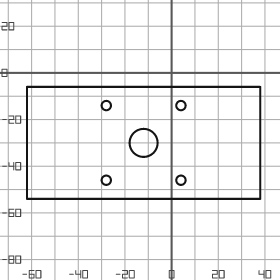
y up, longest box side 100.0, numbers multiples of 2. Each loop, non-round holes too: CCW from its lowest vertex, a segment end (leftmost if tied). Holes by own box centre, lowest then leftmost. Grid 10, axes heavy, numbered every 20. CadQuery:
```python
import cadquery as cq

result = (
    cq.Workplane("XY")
    .moveTo(-62.0, -54.0)
    .lineTo(38.0, -54.0)
    .lineTo(38.0, -6.0)
    .lineTo(-62.0, -6.0)
    .close()
    .moveTo(-28.0, -46.0)
    .circle(2.0)
    .moveTo(4.0, -46.0)
    .circle(2.0)
    .moveTo(-12.0, -30.0)
    .circle(6.0)
    .moveTo(-28.0, -14.0)
    .circle(2.0)
    .moveTo(4.0, -14.0)
    .circle(2.0)
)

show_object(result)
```